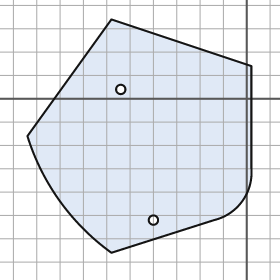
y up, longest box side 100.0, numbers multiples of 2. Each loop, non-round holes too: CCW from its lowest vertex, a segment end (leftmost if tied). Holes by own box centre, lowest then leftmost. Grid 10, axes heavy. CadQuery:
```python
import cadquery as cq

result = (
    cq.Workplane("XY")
    .moveTo(-58.0, -66.0)
    .lineTo(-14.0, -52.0)
    .threePointArc((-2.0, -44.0), (2.0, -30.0))
    .lineTo(2.0, 14.0)
    .lineTo(-58.0, 34.0)
    .lineTo(-94.0, -16.0)
    .threePointArc((-80.0, -44.0), (-58.0, -66.0))
    .close()
    .moveTo(-40.0, -52.0)
    .circle(2.0)
    .moveTo(-54.0, 4.0)
    .circle(2.0)
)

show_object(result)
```